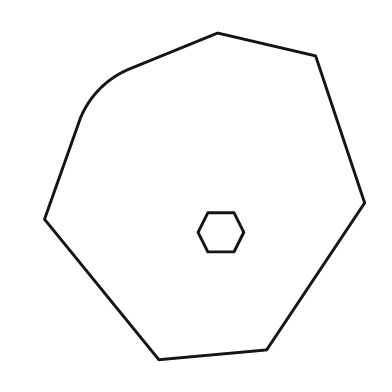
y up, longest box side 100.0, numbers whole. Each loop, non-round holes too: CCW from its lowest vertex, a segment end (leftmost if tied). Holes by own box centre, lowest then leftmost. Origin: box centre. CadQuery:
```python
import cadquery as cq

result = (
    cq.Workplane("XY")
    .moveTo(-14.0, -50.0)
    .lineTo(19.0, -47.0)
    .lineTo(49.0, -2.0)
    .lineTo(34.0, 43.0)
    .lineTo(4.0, 50.0)
    .lineTo(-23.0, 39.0)
    .threePointArc((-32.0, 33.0), (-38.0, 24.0))
    .lineTo(-49.0, -7.0)
    .close()
    .moveTo(1.0, -17.0)
    .lineTo(9.0, -17.0)
    .lineTo(12.0, -11.0)
    .lineTo(9.0, -5.0)
    .lineTo(1.0, -5.0)
    .lineTo(-2.0, -11.0)
    .close()
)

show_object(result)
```